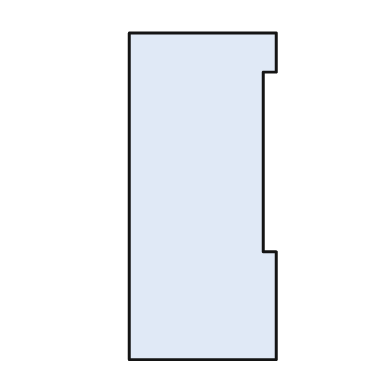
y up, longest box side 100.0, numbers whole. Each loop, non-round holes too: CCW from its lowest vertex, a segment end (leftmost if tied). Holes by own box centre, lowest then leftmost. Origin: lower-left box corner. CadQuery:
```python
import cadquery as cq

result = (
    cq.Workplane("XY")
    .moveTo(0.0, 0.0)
    .lineTo(45.0, 0.0)
    .lineTo(45.0, 33.0)
    .lineTo(41.0, 33.0)
    .lineTo(41.0, 88.0)
    .lineTo(45.0, 88.0)
    .lineTo(45.0, 100.0)
    .lineTo(0.0, 100.0)
    .close()
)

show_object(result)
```